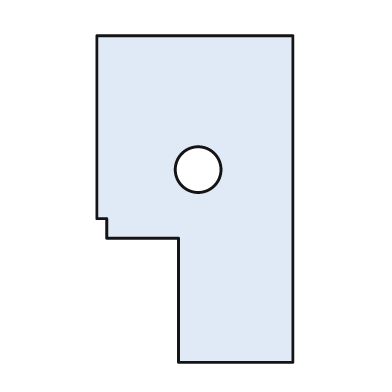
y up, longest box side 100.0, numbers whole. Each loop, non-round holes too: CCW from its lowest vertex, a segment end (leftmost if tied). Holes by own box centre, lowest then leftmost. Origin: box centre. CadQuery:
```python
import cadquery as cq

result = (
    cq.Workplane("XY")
    .moveTo(-5.0, -50.0)
    .lineTo(30.0, -50.0)
    .lineTo(30.0, 50.0)
    .lineTo(-30.0, 50.0)
    .lineTo(-30.0, -6.0)
    .lineTo(-27.0, -6.0)
    .lineTo(-27.0, -12.0)
    .lineTo(-5.0, -12.0)
    .close()
    .moveTo(1.0, 9.0)
    .circle(7.0)
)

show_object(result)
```